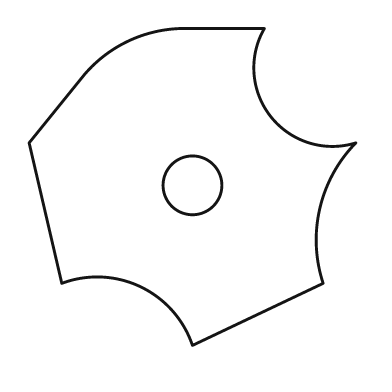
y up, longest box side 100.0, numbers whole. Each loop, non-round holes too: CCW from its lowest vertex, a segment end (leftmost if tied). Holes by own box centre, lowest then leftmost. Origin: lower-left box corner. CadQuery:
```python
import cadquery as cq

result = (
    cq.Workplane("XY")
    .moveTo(50.0, 0.0)
    .lineTo(90.0, 19.0)
    .threePointArc((89.0, 42.0), (100.0, 62.0))
    .threePointArc((74.0, 70.0), (72.0, 97.0))
    .lineTo(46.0, 97.0)
    .threePointArc((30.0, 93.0), (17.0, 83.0))
    .lineTo(0.0, 62.0)
    .lineTo(10.0, 19.0)
    .threePointArc((34.0, 18.0), (50.0, 0.0))
    .close()
    .moveTo(50.0, 49.0)
    .circle(9.0)
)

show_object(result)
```